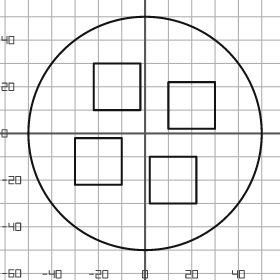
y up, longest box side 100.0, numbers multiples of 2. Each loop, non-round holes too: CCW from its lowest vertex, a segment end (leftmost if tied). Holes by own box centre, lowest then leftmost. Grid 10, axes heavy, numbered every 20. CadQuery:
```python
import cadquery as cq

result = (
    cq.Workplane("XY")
    .moveTo(0.0, 0.0)
    .circle(50.0)
    .moveTo(2.0, -30.0)
    .lineTo(22.0, -30.0)
    .lineTo(22.0, -10.0)
    .lineTo(2.0, -10.0)
    .close()
    .moveTo(-30.0, -22.0)
    .lineTo(-10.0, -22.0)
    .lineTo(-10.0, -2.0)
    .lineTo(-30.0, -2.0)
    .close()
    .moveTo(10.0, 2.0)
    .lineTo(30.0, 2.0)
    .lineTo(30.0, 22.0)
    .lineTo(10.0, 22.0)
    .close()
    .moveTo(-22.0, 10.0)
    .lineTo(-2.0, 10.0)
    .lineTo(-2.0, 30.0)
    .lineTo(-22.0, 30.0)
    .close()
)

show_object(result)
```